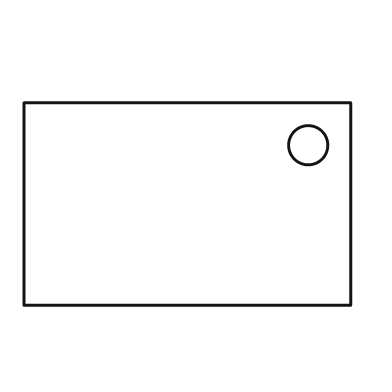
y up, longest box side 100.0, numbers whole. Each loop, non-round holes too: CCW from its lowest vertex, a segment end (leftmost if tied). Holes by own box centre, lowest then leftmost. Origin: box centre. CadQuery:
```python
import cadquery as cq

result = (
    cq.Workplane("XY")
    .moveTo(-50.0, -31.0)
    .lineTo(50.0, -31.0)
    .lineTo(50.0, 31.0)
    .lineTo(-50.0, 31.0)
    .close()
    .moveTo(37.0, 18.0)
    .circle(6.0)
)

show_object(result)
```